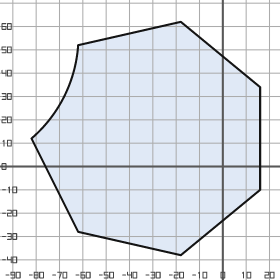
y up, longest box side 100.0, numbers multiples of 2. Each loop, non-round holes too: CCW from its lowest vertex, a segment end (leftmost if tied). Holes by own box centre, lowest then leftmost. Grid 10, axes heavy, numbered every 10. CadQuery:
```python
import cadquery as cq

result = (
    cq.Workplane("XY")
    .moveTo(-18.0, -38.0)
    .lineTo(16.0, -10.0)
    .lineTo(16.0, 34.0)
    .lineTo(-18.0, 62.0)
    .lineTo(-62.0, 52.0)
    .threePointArc((-68.0, 30.0), (-82.0, 12.0))
    .lineTo(-62.0, -28.0)
    .close()
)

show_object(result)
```